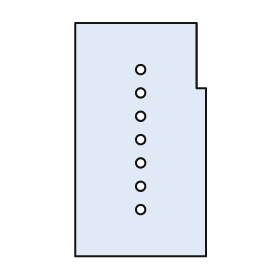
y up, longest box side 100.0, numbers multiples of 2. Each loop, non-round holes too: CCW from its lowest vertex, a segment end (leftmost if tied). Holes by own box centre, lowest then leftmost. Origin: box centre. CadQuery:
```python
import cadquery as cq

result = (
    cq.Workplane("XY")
    .moveTo(-28.0, -50.0)
    .lineTo(28.0, -50.0)
    .lineTo(28.0, 22.0)
    .lineTo(24.0, 22.0)
    .lineTo(24.0, 50.0)
    .lineTo(-28.0, 50.0)
    .close()
    .moveTo(0.0, -30.0)
    .circle(2.0)
    .moveTo(0.0, -20.0)
    .circle(2.0)
    .moveTo(0.0, -10.0)
    .circle(2.0)
    .moveTo(0.0, 0.0)
    .circle(2.0)
    .moveTo(0.0, 10.0)
    .circle(2.0)
    .moveTo(0.0, 20.0)
    .circle(2.0)
    .moveTo(0.0, 30.0)
    .circle(2.0)
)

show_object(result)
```